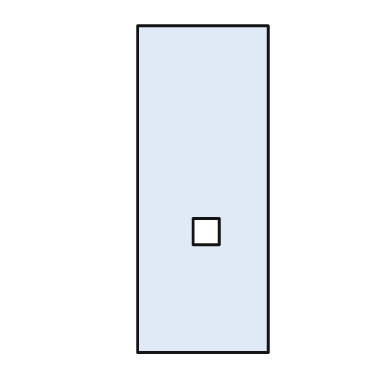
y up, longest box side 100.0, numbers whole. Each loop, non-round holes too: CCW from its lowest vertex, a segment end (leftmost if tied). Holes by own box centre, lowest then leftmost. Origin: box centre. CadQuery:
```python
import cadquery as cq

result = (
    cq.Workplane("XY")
    .moveTo(-20.0, -50.0)
    .lineTo(20.0, -50.0)
    .lineTo(20.0, 50.0)
    .lineTo(-20.0, 50.0)
    .close()
    .moveTo(-3.0, -17.0)
    .lineTo(5.0, -17.0)
    .lineTo(5.0, -9.0)
    .lineTo(-3.0, -9.0)
    .close()
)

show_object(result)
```